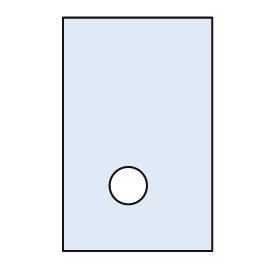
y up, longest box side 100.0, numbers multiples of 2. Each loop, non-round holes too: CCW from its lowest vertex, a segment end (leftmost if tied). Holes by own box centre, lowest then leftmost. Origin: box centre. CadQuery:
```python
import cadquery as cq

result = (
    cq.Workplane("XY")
    .moveTo(-32.0, -50.0)
    .lineTo(32.0, -50.0)
    .lineTo(32.0, 50.0)
    .lineTo(-32.0, 50.0)
    .close()
    .moveTo(-4.0, -22.0)
    .circle(8.0)
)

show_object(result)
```